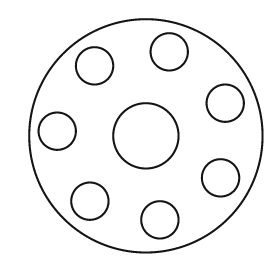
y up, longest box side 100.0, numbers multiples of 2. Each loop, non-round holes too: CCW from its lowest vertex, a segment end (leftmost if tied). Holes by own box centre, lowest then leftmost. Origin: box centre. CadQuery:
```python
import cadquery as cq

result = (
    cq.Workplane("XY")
    .moveTo(0.0, 0.0)
    .circle(50.0)
    .moveTo(6.0, -36.0)
    .circle(8.0)
    .moveTo(-24.0, -28.0)
    .circle(8.0)
    .moveTo(32.0, -18.0)
    .circle(8.0)
    .moveTo(0.0, 0.0)
    .circle(14.0)
    .moveTo(-38.0, 2.0)
    .circle(8.0)
    .moveTo(34.0, 14.0)
    .circle(8.0)
    .moveTo(-22.0, 30.0)
    .circle(8.0)
    .moveTo(10.0, 36.0)
    .circle(8.0)
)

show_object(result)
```